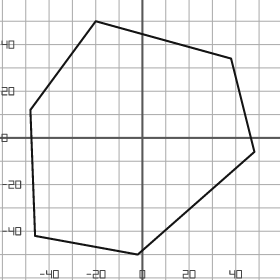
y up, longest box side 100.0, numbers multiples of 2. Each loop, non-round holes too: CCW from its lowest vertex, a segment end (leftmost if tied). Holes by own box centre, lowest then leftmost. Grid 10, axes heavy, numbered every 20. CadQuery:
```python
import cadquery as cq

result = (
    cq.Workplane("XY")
    .moveTo(-2.0, -50.0)
    .lineTo(48.0, -6.0)
    .lineTo(38.0, 34.0)
    .lineTo(-20.0, 50.0)
    .lineTo(-48.0, 12.0)
    .lineTo(-46.0, -42.0)
    .close()
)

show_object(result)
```